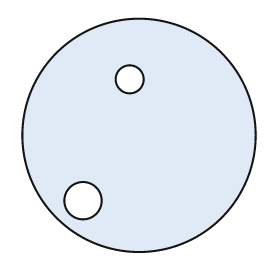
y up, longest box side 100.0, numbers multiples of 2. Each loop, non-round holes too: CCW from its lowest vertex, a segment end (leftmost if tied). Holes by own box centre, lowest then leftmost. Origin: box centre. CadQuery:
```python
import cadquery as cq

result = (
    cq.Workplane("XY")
    .moveTo(0.0, 0.0)
    .circle(50.0)
    .moveTo(-24.0, -28.0)
    .circle(8.0)
    .moveTo(-4.0, 24.0)
    .circle(6.0)
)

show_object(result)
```